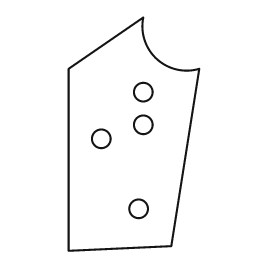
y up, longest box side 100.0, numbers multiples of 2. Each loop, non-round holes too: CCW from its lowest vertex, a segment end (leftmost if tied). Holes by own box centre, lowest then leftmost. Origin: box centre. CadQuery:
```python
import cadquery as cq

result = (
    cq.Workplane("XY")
    .moveTo(-28.0, -50.0)
    .lineTo(16.0, -48.0)
    .lineTo(28.0, 28.0)
    .threePointArc((10.0, 32.0), (4.0, 50.0))
    .lineTo(-28.0, 28.0)
    .close()
    .moveTo(2.0, -32.0)
    .circle(4.0)
    .moveTo(-14.0, -2.0)
    .circle(4.0)
    .moveTo(4.0, 4.0)
    .circle(4.0)
    .moveTo(4.0, 18.0)
    .circle(4.0)
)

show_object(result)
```